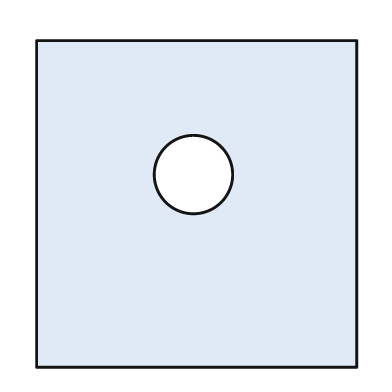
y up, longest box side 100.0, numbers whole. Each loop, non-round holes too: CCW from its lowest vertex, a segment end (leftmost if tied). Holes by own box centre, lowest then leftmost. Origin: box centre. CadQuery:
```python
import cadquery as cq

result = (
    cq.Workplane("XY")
    .moveTo(-49.0, -50.0)
    .lineTo(49.0, -50.0)
    .lineTo(49.0, 50.0)
    .lineTo(-49.0, 50.0)
    .close()
    .moveTo(-1.0, 9.0)
    .circle(12.0)
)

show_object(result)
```